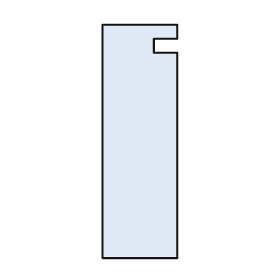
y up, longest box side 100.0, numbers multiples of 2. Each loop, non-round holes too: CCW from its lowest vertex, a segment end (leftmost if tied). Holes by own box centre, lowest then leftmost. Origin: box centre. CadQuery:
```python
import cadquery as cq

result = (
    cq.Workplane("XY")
    .moveTo(-16.0, -50.0)
    .lineTo(16.0, -50.0)
    .lineTo(16.0, 38.0)
    .lineTo(6.0, 38.0)
    .lineTo(6.0, 44.0)
    .lineTo(16.0, 44.0)
    .lineTo(16.0, 50.0)
    .lineTo(-16.0, 50.0)
    .close()
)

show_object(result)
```